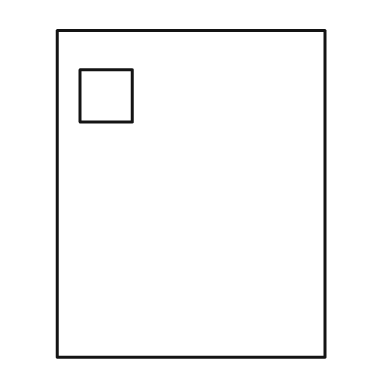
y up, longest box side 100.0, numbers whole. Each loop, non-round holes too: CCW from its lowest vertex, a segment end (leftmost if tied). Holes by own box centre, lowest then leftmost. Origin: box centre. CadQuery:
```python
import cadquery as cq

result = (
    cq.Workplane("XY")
    .moveTo(-41.0, -50.0)
    .lineTo(41.0, -50.0)
    .lineTo(41.0, 50.0)
    .lineTo(-41.0, 50.0)
    .close()
    .moveTo(-34.0, 22.0)
    .lineTo(-18.0, 22.0)
    .lineTo(-18.0, 38.0)
    .lineTo(-34.0, 38.0)
    .close()
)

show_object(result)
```